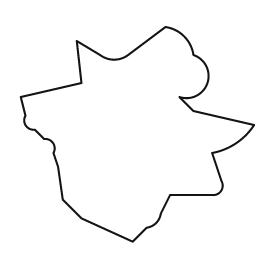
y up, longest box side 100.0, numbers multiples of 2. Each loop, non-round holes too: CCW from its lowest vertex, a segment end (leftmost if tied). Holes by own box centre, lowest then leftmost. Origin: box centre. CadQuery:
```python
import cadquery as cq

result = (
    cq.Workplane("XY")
    .moveTo(-2.0, -46.0)
    .lineTo(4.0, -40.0)
    .threePointArc((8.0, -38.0), (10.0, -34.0))
    .lineTo(14.0, -26.0)
    .lineTo(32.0, -26.0)
    .threePointArc((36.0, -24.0), (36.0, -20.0))
    .lineTo(32.0, -8.0)
    .threePointArc((42.0, -4.0), (50.0, 4.0))
    .lineTo(24.0, 10.0)
    .lineTo(18.0, 16.0)
    .threePointArc((30.0, 22.0), (24.0, 34.0))
    .threePointArc((20.0, 42.0), (12.0, 46.0))
    .lineTo(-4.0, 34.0)
    .threePointArc((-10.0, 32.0), (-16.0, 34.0))
    .lineTo(-26.0, 40.0)
    .lineTo(-24.0, 22.0)
    .lineTo(-50.0, 16.0)
    .lineTo(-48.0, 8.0)
    .threePointArc((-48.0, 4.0), (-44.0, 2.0))
    .lineTo(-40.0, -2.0)
    .threePointArc((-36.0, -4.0), (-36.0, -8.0))
    .lineTo(-34.0, -14.0)
    .lineTo(-32.0, -28.0)
    .lineTo(-24.0, -36.0)
    .close()
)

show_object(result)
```